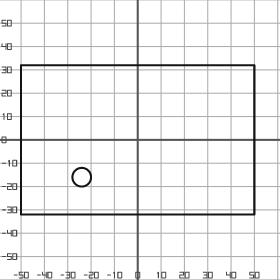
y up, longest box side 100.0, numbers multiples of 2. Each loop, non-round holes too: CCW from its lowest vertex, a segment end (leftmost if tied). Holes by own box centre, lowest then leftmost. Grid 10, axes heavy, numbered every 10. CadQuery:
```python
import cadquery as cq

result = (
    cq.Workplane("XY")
    .moveTo(-50.0, -32.0)
    .lineTo(50.0, -32.0)
    .lineTo(50.0, 32.0)
    .lineTo(-50.0, 32.0)
    .close()
    .moveTo(-24.0, -16.0)
    .circle(4.0)
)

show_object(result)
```